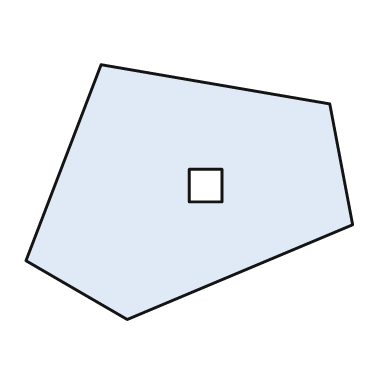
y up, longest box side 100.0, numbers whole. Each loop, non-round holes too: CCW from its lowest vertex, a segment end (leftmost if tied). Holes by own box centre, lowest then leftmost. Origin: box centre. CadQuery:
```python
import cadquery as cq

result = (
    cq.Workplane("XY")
    .moveTo(-19.0, -39.0)
    .lineTo(50.0, -10.0)
    .lineTo(43.0, 27.0)
    .lineTo(-27.0, 39.0)
    .lineTo(-50.0, -21.0)
    .close()
    .moveTo(0.0, -3.0)
    .lineTo(10.0, -3.0)
    .lineTo(10.0, 7.0)
    .lineTo(0.0, 7.0)
    .close()
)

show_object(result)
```